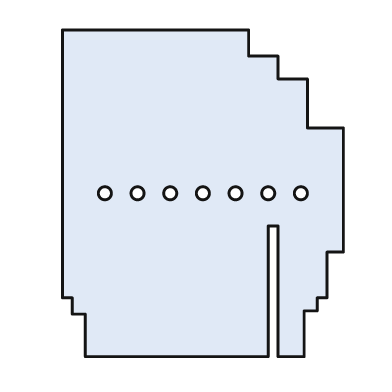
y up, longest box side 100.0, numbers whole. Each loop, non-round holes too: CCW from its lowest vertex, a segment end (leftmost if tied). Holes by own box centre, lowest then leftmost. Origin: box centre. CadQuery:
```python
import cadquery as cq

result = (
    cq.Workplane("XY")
    .moveTo(-36.0, -50.0)
    .lineTo(20.0, -50.0)
    .lineTo(20.0, -10.0)
    .lineTo(23.0, -10.0)
    .lineTo(23.0, -50.0)
    .lineTo(31.0, -50.0)
    .lineTo(31.0, -36.0)
    .lineTo(35.0, -36.0)
    .lineTo(35.0, -32.0)
    .lineTo(38.0, -32.0)
    .lineTo(38.0, -18.0)
    .lineTo(43.0, -18.0)
    .lineTo(43.0, 20.0)
    .lineTo(32.0, 20.0)
    .lineTo(32.0, 35.0)
    .lineTo(23.0, 35.0)
    .lineTo(23.0, 42.0)
    .lineTo(14.0, 42.0)
    .lineTo(14.0, 50.0)
    .lineTo(-43.0, 50.0)
    .lineTo(-43.0, -32.0)
    .lineTo(-40.0, -32.0)
    .lineTo(-40.0, -37.0)
    .lineTo(-36.0, -37.0)
    .close()
    .moveTo(-30.0, 0.0)
    .circle(2.0)
    .moveTo(-20.0, 0.0)
    .circle(2.0)
    .moveTo(-10.0, 0.0)
    .circle(2.0)
    .moveTo(0.0, 0.0)
    .circle(2.0)
    .moveTo(10.0, 0.0)
    .circle(2.0)
    .moveTo(20.0, 0.0)
    .circle(2.0)
    .moveTo(30.0, 0.0)
    .circle(2.0)
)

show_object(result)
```